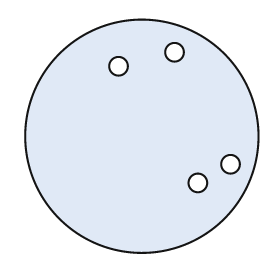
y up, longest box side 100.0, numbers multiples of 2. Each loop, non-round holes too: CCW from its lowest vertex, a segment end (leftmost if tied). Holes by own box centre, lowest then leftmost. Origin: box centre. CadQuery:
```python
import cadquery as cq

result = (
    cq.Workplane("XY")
    .moveTo(0.0, 0.0)
    .circle(50.0)
    .moveTo(24.0, -20.0)
    .circle(4.0)
    .moveTo(38.0, -12.0)
    .circle(4.0)
    .moveTo(-10.0, 30.0)
    .circle(4.0)
    .moveTo(14.0, 36.0)
    .circle(4.0)
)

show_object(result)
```